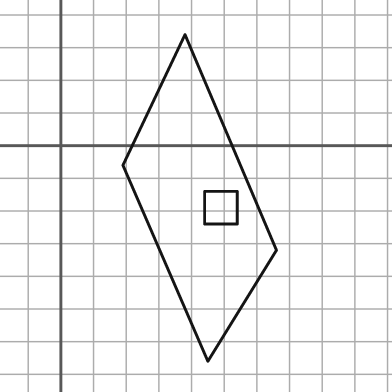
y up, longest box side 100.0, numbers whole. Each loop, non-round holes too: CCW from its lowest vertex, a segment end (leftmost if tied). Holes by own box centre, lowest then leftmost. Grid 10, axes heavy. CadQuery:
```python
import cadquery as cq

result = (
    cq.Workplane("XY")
    .moveTo(45.0, -66.0)
    .lineTo(66.0, -32.0)
    .lineTo(38.0, 34.0)
    .lineTo(19.0, -6.0)
    .close()
    .moveTo(44.0, -24.0)
    .lineTo(54.0, -24.0)
    .lineTo(54.0, -14.0)
    .lineTo(44.0, -14.0)
    .close()
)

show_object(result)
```